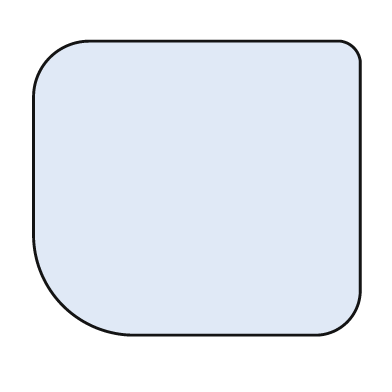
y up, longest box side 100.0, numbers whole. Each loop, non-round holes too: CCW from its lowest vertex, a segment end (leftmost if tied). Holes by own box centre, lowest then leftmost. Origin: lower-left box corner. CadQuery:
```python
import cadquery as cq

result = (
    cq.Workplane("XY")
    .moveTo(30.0, 0.0)
    .lineTo(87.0, 0.0)
    .threePointArc((96.0, 4.0), (100.0, 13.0))
    .lineTo(100.0, 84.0)
    .threePointArc((98.0, 88.0), (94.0, 90.0))
    .lineTo(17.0, 90.0)
    .threePointArc((5.0, 85.0), (0.0, 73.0))
    .lineTo(0.0, 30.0)
    .threePointArc((9.0, 9.0), (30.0, 0.0))
    .close()
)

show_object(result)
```